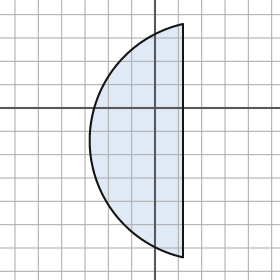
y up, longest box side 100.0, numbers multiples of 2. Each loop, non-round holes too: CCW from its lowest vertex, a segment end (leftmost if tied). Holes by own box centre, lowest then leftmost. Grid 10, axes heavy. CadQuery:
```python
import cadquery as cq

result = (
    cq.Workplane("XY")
    .moveTo(12.0, -64.0)
    .lineTo(12.0, 36.0)
    .threePointArc((-28.0, -14.0), (12.0, -64.0))
    .close()
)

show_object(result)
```